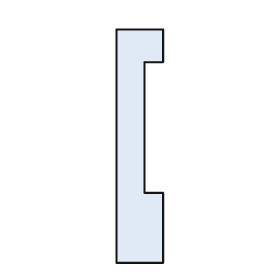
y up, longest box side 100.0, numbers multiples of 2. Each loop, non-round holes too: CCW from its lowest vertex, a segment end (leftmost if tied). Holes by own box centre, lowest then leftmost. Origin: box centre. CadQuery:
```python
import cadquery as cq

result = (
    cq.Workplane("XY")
    .moveTo(-10.0, -50.0)
    .lineTo(10.0, -50.0)
    .lineTo(10.0, -20.0)
    .lineTo(2.0, -20.0)
    .lineTo(2.0, 36.0)
    .lineTo(10.0, 36.0)
    .lineTo(10.0, 50.0)
    .lineTo(-10.0, 50.0)
    .close()
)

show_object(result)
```